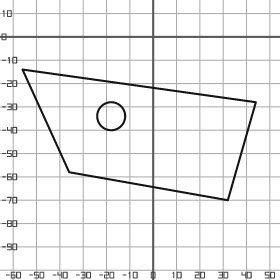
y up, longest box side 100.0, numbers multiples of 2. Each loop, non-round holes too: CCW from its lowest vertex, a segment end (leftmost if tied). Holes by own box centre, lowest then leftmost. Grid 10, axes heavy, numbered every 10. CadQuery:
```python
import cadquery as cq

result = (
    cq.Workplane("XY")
    .moveTo(32.0, -70.0)
    .lineTo(44.0, -28.0)
    .lineTo(-56.0, -14.0)
    .lineTo(-36.0, -58.0)
    .close()
    .moveTo(-18.0, -34.0)
    .circle(6.0)
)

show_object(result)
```